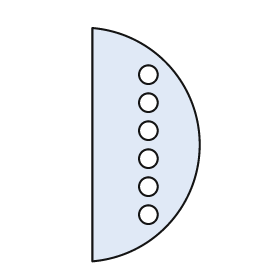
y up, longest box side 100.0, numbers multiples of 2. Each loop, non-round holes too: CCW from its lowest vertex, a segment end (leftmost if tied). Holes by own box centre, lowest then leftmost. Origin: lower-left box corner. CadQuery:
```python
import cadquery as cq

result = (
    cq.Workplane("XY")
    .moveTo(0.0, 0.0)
    .threePointArc((46.0, 50.0), (0.0, 100.0))
    .close()
    .moveTo(24.0, 20.0)
    .circle(4.0)
    .moveTo(24.0, 32.0)
    .circle(4.0)
    .moveTo(24.0, 44.0)
    .circle(4.0)
    .moveTo(24.0, 56.0)
    .circle(4.0)
    .moveTo(24.0, 68.0)
    .circle(4.0)
    .moveTo(24.0, 80.0)
    .circle(4.0)
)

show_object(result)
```